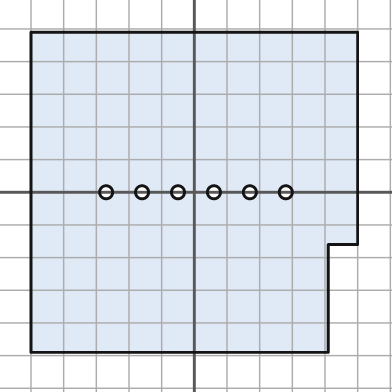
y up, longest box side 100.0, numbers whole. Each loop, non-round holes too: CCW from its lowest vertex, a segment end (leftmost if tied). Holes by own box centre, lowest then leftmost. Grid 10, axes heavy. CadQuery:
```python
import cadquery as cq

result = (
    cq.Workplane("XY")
    .moveTo(-50.0, -49.0)
    .lineTo(41.0, -49.0)
    .lineTo(41.0, -16.0)
    .lineTo(50.0, -16.0)
    .lineTo(50.0, 49.0)
    .lineTo(-50.0, 49.0)
    .close()
    .moveTo(-27.0, 0.0)
    .circle(2.0)
    .moveTo(-16.0, 0.0)
    .circle(2.0)
    .moveTo(-5.0, 0.0)
    .circle(2.0)
    .moveTo(6.0, 0.0)
    .circle(2.0)
    .moveTo(17.0, 0.0)
    .circle(2.0)
    .moveTo(28.0, 0.0)
    .circle(2.0)
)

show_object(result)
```